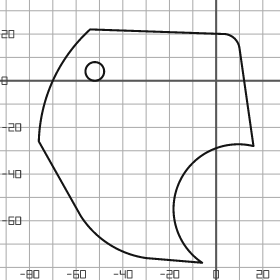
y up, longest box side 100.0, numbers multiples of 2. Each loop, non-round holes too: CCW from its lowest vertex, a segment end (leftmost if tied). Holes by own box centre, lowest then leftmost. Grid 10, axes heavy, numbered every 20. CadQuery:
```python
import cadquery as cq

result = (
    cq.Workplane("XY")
    .moveTo(-6.0, -78.0)
    .threePointArc((-16.0, -44.0), (16.0, -28.0))
    .lineTo(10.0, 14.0)
    .threePointArc((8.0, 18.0), (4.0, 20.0))
    .lineTo(-54.0, 22.0)
    .threePointArc((-70.0, 0.0), (-76.0, -26.0))
    .lineTo(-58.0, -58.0)
    .threePointArc((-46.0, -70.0), (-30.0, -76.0))
    .close()
    .moveTo(-52.0, 4.0)
    .circle(4.0)
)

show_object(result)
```